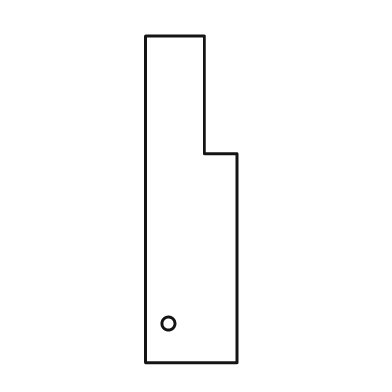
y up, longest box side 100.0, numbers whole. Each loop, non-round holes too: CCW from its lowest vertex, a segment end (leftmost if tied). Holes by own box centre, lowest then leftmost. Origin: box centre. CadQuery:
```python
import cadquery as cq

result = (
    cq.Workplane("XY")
    .moveTo(-14.0, -50.0)
    .lineTo(14.0, -50.0)
    .lineTo(14.0, 14.0)
    .lineTo(4.0, 14.0)
    .lineTo(4.0, 50.0)
    .lineTo(-14.0, 50.0)
    .close()
    .moveTo(-7.0, -38.0)
    .circle(2.0)
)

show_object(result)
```